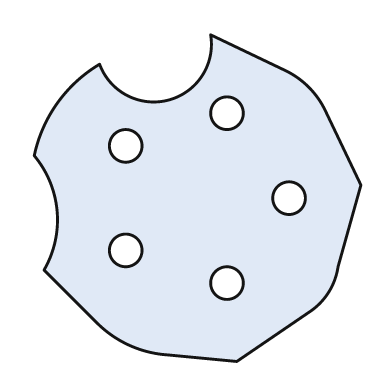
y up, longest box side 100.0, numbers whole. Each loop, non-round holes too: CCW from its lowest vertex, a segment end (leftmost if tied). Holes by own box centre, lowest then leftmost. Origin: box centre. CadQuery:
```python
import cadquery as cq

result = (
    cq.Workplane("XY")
    .moveTo(12.0, -50.0)
    .lineTo(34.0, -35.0)
    .threePointArc((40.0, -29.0), (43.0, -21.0))
    .lineTo(50.0, 4.0)
    .lineTo(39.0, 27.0)
    .threePointArc((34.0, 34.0), (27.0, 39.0))
    .lineTo(4.0, 50.0)
    .threePointArc((-9.0, 30.0), (-30.0, 41.0))
    .threePointArc((-43.0, 29.0), (-50.0, 13.0))
    .threePointArc((-43.0, -4.0), (-47.0, -22.0))
    .lineTo(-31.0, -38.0)
    .threePointArc((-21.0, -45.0), (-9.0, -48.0))
    .close()
    .moveTo(9.0, -26.0)
    .circle(5.0)
    .moveTo(-22.0, -16.0)
    .circle(5.0)
    .moveTo(28.0, 0.0)
    .circle(5.0)
    .moveTo(-22.0, 16.0)
    .circle(5.0)
    .moveTo(9.0, 26.0)
    .circle(5.0)
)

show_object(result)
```